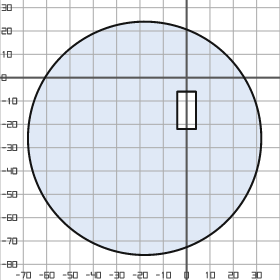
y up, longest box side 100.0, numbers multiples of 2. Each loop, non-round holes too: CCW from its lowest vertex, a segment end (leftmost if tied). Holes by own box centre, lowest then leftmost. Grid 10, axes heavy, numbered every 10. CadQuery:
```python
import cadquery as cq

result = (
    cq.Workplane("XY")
    .moveTo(-18.0, -26.0)
    .circle(50.0)
    .moveTo(-4.0, -22.0)
    .lineTo(4.0, -22.0)
    .lineTo(4.0, -6.0)
    .lineTo(-4.0, -6.0)
    .close()
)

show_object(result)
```